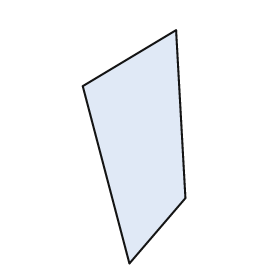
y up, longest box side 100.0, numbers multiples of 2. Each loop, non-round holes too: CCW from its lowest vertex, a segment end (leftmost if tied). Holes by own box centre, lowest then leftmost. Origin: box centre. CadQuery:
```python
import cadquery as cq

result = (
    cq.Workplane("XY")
    .moveTo(-2.0, -50.0)
    .lineTo(22.0, -22.0)
    .lineTo(18.0, 50.0)
    .lineTo(-22.0, 26.0)
    .close()
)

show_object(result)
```